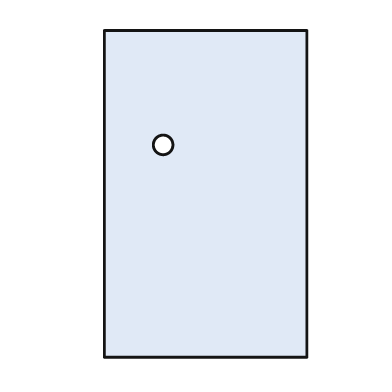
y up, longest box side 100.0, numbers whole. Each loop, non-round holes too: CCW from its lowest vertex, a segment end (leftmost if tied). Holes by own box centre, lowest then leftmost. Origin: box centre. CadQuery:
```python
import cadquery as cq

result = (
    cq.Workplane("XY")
    .moveTo(-31.0, -50.0)
    .lineTo(31.0, -50.0)
    .lineTo(31.0, 50.0)
    .lineTo(-31.0, 50.0)
    .close()
    .moveTo(-13.0, 15.0)
    .circle(3.0)
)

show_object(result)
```